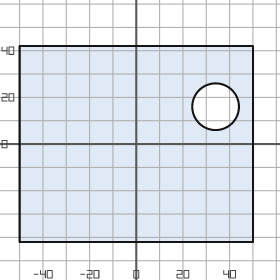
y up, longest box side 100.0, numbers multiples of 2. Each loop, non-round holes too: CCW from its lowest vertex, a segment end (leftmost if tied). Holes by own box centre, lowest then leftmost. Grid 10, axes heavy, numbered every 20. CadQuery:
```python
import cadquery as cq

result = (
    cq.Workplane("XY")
    .moveTo(-50.0, -42.0)
    .lineTo(50.0, -42.0)
    .lineTo(50.0, 42.0)
    .lineTo(-50.0, 42.0)
    .close()
    .moveTo(34.0, 16.0)
    .circle(10.0)
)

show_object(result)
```